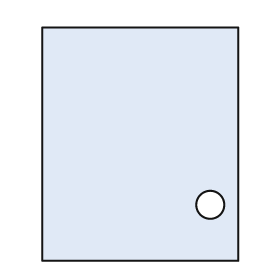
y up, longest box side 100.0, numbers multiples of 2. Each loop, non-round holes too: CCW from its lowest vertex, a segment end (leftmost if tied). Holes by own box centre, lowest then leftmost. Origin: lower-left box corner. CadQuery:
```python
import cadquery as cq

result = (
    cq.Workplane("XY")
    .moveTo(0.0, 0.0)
    .lineTo(84.0, 0.0)
    .lineTo(84.0, 100.0)
    .lineTo(0.0, 100.0)
    .close()
    .moveTo(72.0, 24.0)
    .circle(6.0)
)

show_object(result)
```